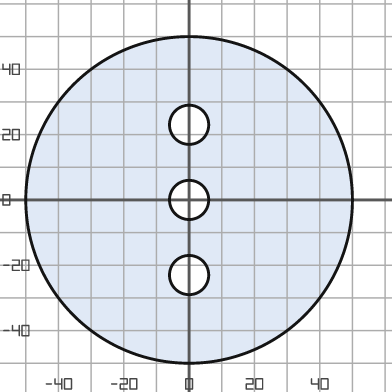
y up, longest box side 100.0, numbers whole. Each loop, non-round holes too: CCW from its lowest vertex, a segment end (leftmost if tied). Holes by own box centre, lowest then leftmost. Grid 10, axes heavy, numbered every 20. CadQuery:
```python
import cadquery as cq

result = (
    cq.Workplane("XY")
    .moveTo(0.0, 0.0)
    .circle(50.0)
    .moveTo(0.0, -23.0)
    .circle(6.0)
    .moveTo(0.0, 0.0)
    .circle(6.0)
    .moveTo(0.0, 23.0)
    .circle(6.0)
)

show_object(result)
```